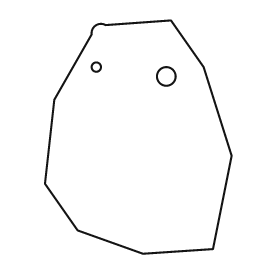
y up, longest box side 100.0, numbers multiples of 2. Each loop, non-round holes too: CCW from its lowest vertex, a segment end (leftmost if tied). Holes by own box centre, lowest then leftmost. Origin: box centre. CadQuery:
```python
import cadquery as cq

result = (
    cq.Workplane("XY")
    .moveTo(2.0, -50.0)
    .lineTo(32.0, -48.0)
    .lineTo(40.0, -8.0)
    .lineTo(28.0, 30.0)
    .lineTo(14.0, 50.0)
    .lineTo(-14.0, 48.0)
    .threePointArc((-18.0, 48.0), (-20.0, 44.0))
    .lineTo(-36.0, 16.0)
    .lineTo(-40.0, -20.0)
    .lineTo(-26.0, -40.0)
    .close()
    .moveTo(12.0, 26.0)
    .circle(4.0)
    .moveTo(-18.0, 30.0)
    .circle(2.0)
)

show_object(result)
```